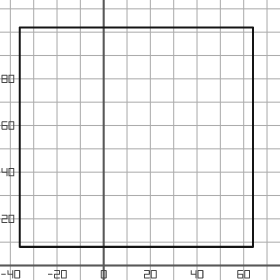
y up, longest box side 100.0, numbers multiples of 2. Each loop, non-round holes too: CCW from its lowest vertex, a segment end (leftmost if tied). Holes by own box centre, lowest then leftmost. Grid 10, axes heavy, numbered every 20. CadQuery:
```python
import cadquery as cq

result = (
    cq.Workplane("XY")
    .moveTo(-36.0, 8.0)
    .lineTo(64.0, 8.0)
    .lineTo(64.0, 102.0)
    .lineTo(-36.0, 102.0)
    .close()
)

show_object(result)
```